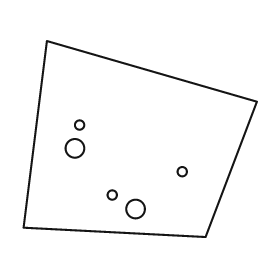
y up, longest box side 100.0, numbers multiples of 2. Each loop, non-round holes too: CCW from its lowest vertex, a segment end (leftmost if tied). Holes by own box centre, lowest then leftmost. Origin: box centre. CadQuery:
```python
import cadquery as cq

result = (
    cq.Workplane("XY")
    .moveTo(28.0, -42.0)
    .lineTo(50.0, 16.0)
    .lineTo(-40.0, 42.0)
    .lineTo(-50.0, -38.0)
    .close()
    .moveTo(-2.0, -30.0)
    .circle(4.0)
    .moveTo(-12.0, -24.0)
    .circle(2.0)
    .moveTo(18.0, -14.0)
    .circle(2.0)
    .moveTo(-28.0, -4.0)
    .circle(4.0)
    .moveTo(-26.0, 6.0)
    .circle(2.0)
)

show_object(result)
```